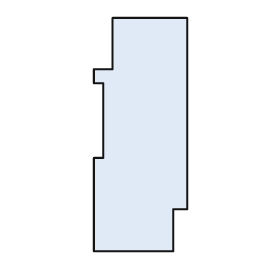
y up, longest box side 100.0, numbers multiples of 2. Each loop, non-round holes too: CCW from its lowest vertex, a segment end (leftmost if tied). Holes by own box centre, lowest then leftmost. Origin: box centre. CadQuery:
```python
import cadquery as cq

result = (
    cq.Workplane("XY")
    .moveTo(-20.0, -50.0)
    .lineTo(14.0, -50.0)
    .lineTo(14.0, -32.0)
    .lineTo(20.0, -32.0)
    .lineTo(20.0, 50.0)
    .lineTo(-12.0, 50.0)
    .lineTo(-12.0, 28.0)
    .lineTo(-20.0, 28.0)
    .lineTo(-20.0, 22.0)
    .lineTo(-16.0, 22.0)
    .lineTo(-16.0, -10.0)
    .lineTo(-20.0, -10.0)
    .close()
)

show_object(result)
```